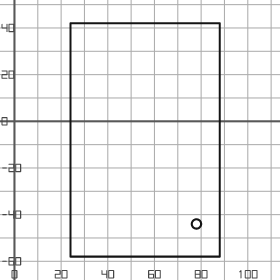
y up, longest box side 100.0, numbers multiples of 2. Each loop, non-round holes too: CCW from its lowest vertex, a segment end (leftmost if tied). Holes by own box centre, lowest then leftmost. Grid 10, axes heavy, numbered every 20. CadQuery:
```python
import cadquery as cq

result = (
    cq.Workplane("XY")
    .moveTo(24.0, -58.0)
    .lineTo(88.0, -58.0)
    .lineTo(88.0, 42.0)
    .lineTo(24.0, 42.0)
    .close()
    .moveTo(78.0, -44.0)
    .circle(2.0)
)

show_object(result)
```